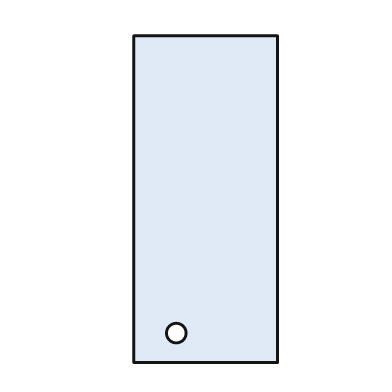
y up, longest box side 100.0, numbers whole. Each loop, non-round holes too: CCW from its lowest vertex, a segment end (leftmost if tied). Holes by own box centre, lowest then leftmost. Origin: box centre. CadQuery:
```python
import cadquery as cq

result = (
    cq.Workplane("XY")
    .moveTo(-22.0, -50.0)
    .lineTo(22.0, -50.0)
    .lineTo(22.0, 50.0)
    .lineTo(-22.0, 50.0)
    .close()
    .moveTo(-9.0, -41.0)
    .circle(3.0)
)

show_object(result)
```